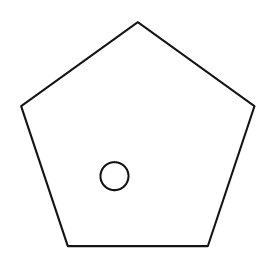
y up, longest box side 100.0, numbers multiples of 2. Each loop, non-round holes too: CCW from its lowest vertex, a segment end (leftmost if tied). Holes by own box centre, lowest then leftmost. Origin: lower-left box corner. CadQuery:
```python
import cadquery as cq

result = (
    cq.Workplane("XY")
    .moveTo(20.0, 0.0)
    .lineTo(80.0, 0.0)
    .lineTo(100.0, 60.0)
    .lineTo(50.0, 96.0)
    .lineTo(0.0, 60.0)
    .close()
    .moveTo(40.0, 30.0)
    .circle(6.0)
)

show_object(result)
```